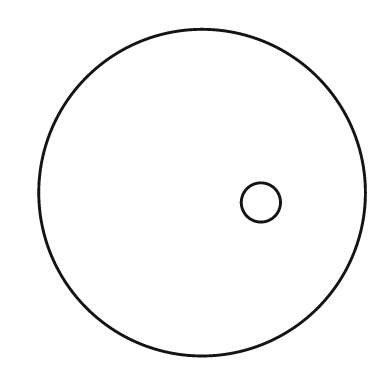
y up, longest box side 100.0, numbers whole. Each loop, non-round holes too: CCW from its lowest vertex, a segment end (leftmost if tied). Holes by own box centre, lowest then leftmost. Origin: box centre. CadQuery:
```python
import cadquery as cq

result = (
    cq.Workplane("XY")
    .moveTo(0.0, 0.0)
    .circle(50.0)
    .moveTo(18.0, -3.0)
    .circle(6.0)
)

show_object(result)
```